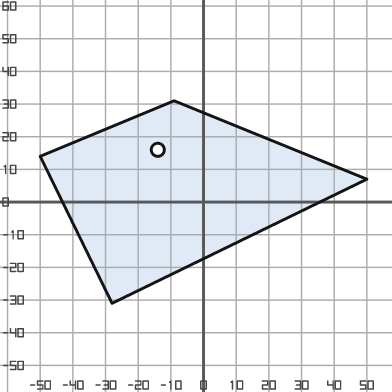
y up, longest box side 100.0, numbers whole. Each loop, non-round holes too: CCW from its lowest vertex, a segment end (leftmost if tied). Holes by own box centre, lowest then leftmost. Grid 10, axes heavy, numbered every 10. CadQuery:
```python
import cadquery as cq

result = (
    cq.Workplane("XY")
    .moveTo(-28.0, -31.0)
    .lineTo(50.0, 7.0)
    .lineTo(-9.0, 31.0)
    .lineTo(-50.0, 14.0)
    .close()
    .moveTo(-14.0, 16.0)
    .circle(2.0)
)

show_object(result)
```